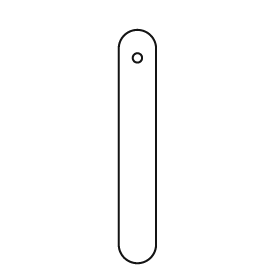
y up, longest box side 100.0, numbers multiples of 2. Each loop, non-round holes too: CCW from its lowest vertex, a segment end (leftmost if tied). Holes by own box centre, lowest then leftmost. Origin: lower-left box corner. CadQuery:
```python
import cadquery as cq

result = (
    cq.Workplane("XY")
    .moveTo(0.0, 8.0)
    .threePointArc((8.0, 0.0), (16.0, 8.0))
    .lineTo(16.0, 92.0)
    .threePointArc((8.0, 100.0), (0.0, 92.0))
    .close()
    .moveTo(8.0, 88.0)
    .circle(2.0)
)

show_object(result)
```